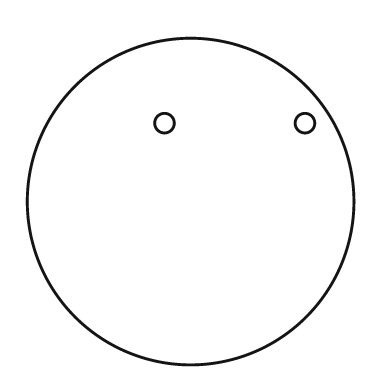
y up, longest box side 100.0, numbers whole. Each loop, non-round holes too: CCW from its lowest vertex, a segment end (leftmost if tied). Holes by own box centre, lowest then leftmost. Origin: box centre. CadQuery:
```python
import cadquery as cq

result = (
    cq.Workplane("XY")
    .moveTo(0.0, 0.0)
    .circle(50.0)
    .moveTo(-8.0, 24.0)
    .circle(3.0)
    .moveTo(35.0, 24.0)
    .circle(3.0)
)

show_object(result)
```